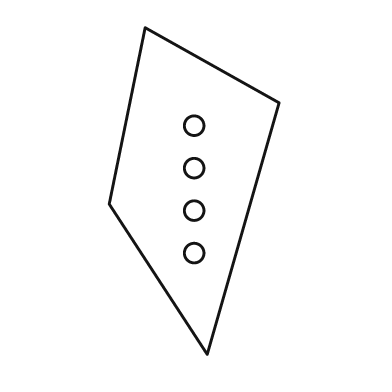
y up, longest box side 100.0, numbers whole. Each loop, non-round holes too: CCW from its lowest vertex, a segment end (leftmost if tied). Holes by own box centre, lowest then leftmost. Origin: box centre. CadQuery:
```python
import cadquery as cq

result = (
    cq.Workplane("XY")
    .moveTo(4.0, -50.0)
    .lineTo(26.0, 27.0)
    .lineTo(-15.0, 50.0)
    .lineTo(-26.0, -4.0)
    .close()
    .moveTo(0.0, -19.0)
    .circle(3.0)
    .moveTo(0.0, -6.0)
    .circle(3.0)
    .moveTo(0.0, 7.0)
    .circle(3.0)
    .moveTo(0.0, 20.0)
    .circle(3.0)
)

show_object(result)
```